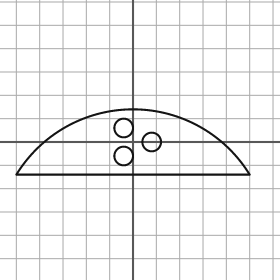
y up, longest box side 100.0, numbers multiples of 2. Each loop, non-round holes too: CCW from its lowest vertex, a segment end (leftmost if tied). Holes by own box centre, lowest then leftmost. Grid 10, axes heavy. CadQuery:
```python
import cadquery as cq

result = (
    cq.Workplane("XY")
    .moveTo(-50.0, -14.0)
    .lineTo(50.0, -14.0)
    .threePointArc((0.0, 14.0), (-50.0, -14.0))
    .close()
    .moveTo(-4.0, -6.0)
    .circle(4.0)
    .moveTo(8.0, 0.0)
    .circle(4.0)
    .moveTo(-4.0, 6.0)
    .circle(4.0)
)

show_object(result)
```